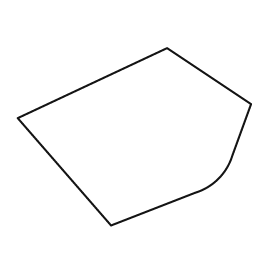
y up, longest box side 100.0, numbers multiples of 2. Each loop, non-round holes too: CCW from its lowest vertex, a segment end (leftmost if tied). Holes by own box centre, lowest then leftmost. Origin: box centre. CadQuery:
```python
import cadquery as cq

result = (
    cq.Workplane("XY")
    .moveTo(-10.0, -38.0)
    .lineTo(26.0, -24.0)
    .threePointArc((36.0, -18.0), (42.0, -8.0))
    .lineTo(50.0, 14.0)
    .lineTo(14.0, 38.0)
    .lineTo(-50.0, 8.0)
    .close()
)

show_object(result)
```